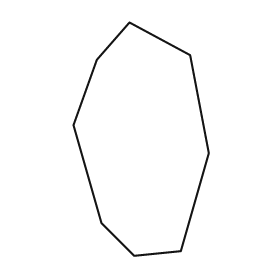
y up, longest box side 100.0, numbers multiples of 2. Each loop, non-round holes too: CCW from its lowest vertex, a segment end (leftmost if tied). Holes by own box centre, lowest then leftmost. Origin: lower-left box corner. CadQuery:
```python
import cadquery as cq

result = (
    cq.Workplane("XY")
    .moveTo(26.0, 0.0)
    .lineTo(46.0, 2.0)
    .lineTo(58.0, 44.0)
    .lineTo(50.0, 86.0)
    .lineTo(24.0, 100.0)
    .lineTo(10.0, 84.0)
    .lineTo(0.0, 56.0)
    .lineTo(12.0, 14.0)
    .close()
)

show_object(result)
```